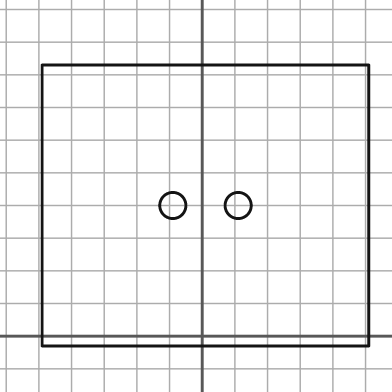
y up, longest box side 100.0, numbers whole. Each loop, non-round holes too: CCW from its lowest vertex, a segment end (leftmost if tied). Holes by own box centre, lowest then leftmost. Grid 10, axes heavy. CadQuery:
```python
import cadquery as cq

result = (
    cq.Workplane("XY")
    .moveTo(-49.0, -3.0)
    .lineTo(51.0, -3.0)
    .lineTo(51.0, 83.0)
    .lineTo(-49.0, 83.0)
    .close()
    .moveTo(-9.0, 40.0)
    .circle(4.0)
    .moveTo(11.0, 40.0)
    .circle(4.0)
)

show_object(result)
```